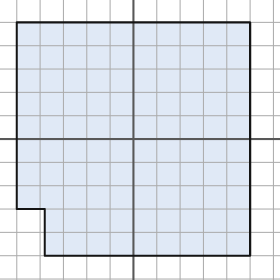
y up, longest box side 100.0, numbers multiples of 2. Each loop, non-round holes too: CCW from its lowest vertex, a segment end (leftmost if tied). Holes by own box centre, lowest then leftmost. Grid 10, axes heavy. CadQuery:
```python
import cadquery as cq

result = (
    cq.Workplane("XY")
    .moveTo(-38.0, -50.0)
    .lineTo(50.0, -50.0)
    .lineTo(50.0, 50.0)
    .lineTo(-50.0, 50.0)
    .lineTo(-50.0, -30.0)
    .lineTo(-38.0, -30.0)
    .close()
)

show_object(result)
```